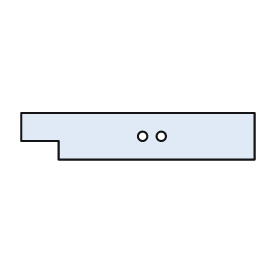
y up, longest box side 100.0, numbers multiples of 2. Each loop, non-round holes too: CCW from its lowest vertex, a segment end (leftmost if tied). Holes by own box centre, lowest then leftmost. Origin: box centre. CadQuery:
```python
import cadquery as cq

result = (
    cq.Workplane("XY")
    .moveTo(-34.0, -10.0)
    .lineTo(50.0, -10.0)
    .lineTo(50.0, 10.0)
    .lineTo(-50.0, 10.0)
    .lineTo(-50.0, -2.0)
    .lineTo(-34.0, -2.0)
    .close()
    .moveTo(2.0, 0.0)
    .circle(2.0)
    .moveTo(10.0, 0.0)
    .circle(2.0)
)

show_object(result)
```